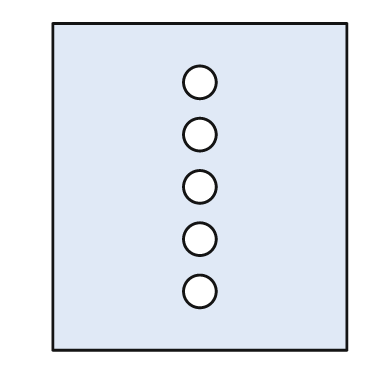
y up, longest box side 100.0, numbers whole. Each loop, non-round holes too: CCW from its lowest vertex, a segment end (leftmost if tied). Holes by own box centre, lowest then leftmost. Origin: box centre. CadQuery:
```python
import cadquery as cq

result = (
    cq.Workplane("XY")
    .moveTo(-45.0, -50.0)
    .lineTo(45.0, -50.0)
    .lineTo(45.0, 50.0)
    .lineTo(-45.0, 50.0)
    .close()
    .moveTo(0.0, -32.0)
    .circle(5.0)
    .moveTo(0.0, -16.0)
    .circle(5.0)
    .moveTo(0.0, 0.0)
    .circle(5.0)
    .moveTo(0.0, 16.0)
    .circle(5.0)
    .moveTo(0.0, 32.0)
    .circle(5.0)
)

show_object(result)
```